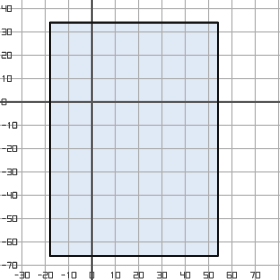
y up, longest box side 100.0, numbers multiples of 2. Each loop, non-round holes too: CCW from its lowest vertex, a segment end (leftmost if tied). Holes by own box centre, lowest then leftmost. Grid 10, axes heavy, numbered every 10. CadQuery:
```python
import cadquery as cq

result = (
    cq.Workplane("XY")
    .moveTo(-18.0, -66.0)
    .lineTo(54.0, -66.0)
    .lineTo(54.0, 34.0)
    .lineTo(-18.0, 34.0)
    .close()
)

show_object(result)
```